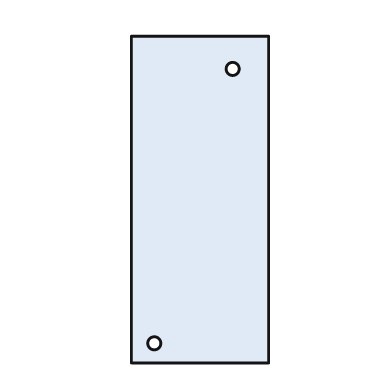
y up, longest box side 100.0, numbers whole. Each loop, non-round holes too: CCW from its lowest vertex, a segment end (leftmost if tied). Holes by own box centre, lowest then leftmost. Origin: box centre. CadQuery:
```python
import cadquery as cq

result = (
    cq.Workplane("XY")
    .moveTo(-21.0, -50.0)
    .lineTo(21.0, -50.0)
    .lineTo(21.0, 50.0)
    .lineTo(-21.0, 50.0)
    .close()
    .moveTo(-14.0, -44.0)
    .circle(2.0)
    .moveTo(10.0, 40.0)
    .circle(2.0)
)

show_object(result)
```